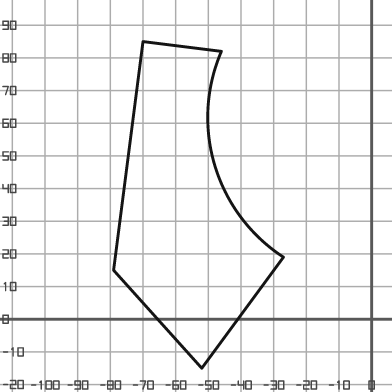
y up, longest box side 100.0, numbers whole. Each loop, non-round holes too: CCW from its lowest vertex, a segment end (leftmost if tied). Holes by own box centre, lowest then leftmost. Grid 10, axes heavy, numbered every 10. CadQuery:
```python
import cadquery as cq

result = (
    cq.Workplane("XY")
    .moveTo(-52.0, -15.0)
    .lineTo(-27.0, 19.0)
    .threePointArc((-48.0, 47.0), (-46.0, 82.0))
    .lineTo(-70.0, 85.0)
    .lineTo(-79.0, 15.0)
    .close()
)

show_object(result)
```